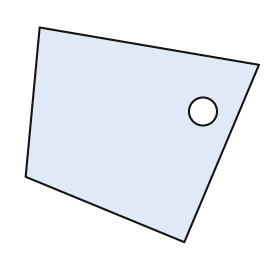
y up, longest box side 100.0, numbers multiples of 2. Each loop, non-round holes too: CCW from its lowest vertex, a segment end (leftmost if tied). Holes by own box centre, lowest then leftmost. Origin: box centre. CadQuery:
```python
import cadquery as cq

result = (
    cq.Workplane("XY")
    .moveTo(18.0, -46.0)
    .lineTo(50.0, 30.0)
    .lineTo(-44.0, 46.0)
    .lineTo(-50.0, -18.0)
    .close()
    .moveTo(26.0, 10.0)
    .circle(6.0)
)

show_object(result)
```